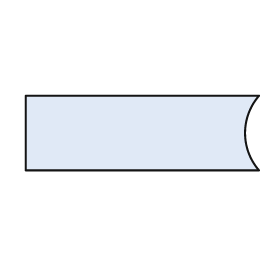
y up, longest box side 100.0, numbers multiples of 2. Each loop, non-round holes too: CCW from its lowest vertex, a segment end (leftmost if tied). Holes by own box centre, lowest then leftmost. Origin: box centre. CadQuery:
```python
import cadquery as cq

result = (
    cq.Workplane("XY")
    .moveTo(-50.0, -16.0)
    .lineTo(50.0, -16.0)
    .threePointArc((44.0, 0.0), (50.0, 16.0))
    .lineTo(-50.0, 16.0)
    .close()
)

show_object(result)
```